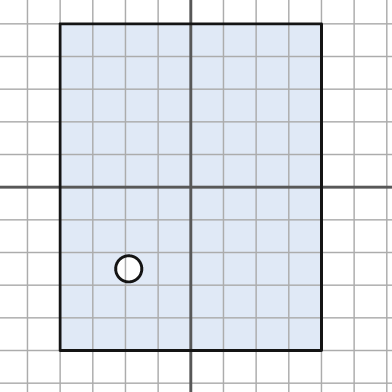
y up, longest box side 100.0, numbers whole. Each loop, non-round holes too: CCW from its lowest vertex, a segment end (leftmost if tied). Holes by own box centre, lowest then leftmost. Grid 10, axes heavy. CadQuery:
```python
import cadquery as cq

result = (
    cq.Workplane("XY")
    .moveTo(-40.0, -50.0)
    .lineTo(40.0, -50.0)
    .lineTo(40.0, 50.0)
    .lineTo(-40.0, 50.0)
    .close()
    .moveTo(-19.0, -25.0)
    .circle(4.0)
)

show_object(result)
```